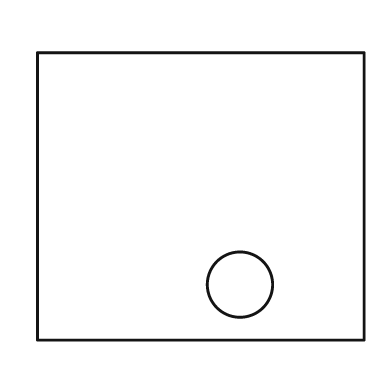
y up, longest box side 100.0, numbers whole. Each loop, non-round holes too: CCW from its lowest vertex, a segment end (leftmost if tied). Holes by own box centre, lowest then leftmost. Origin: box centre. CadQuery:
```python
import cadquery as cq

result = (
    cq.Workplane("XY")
    .moveTo(-50.0, -44.0)
    .lineTo(50.0, -44.0)
    .lineTo(50.0, 44.0)
    .lineTo(-50.0, 44.0)
    .close()
    .moveTo(12.0, -27.0)
    .circle(10.0)
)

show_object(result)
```